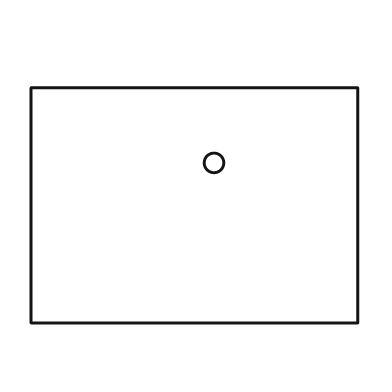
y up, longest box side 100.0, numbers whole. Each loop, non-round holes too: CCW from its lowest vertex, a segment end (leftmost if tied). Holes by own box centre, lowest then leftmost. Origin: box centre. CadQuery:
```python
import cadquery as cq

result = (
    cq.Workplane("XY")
    .moveTo(-50.0, -36.0)
    .lineTo(50.0, -36.0)
    .lineTo(50.0, 36.0)
    .lineTo(-50.0, 36.0)
    .close()
    .moveTo(6.0, 13.0)
    .circle(3.0)
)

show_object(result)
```